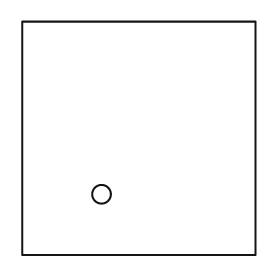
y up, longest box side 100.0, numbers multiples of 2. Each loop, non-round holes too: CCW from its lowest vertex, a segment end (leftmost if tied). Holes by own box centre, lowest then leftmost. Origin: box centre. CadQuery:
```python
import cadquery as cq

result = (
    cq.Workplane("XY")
    .moveTo(-50.0, -50.0)
    .lineTo(50.0, -50.0)
    .lineTo(50.0, 50.0)
    .lineTo(-50.0, 50.0)
    .close()
    .moveTo(-16.0, -24.0)
    .circle(4.0)
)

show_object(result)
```